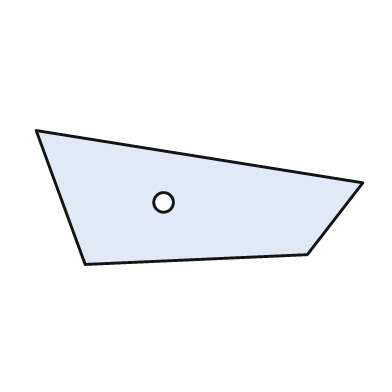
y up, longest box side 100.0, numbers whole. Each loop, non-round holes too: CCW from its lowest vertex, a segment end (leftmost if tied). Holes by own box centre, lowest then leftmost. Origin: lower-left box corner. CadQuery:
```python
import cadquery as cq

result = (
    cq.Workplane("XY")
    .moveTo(15.0, 0.0)
    .lineTo(83.0, 3.0)
    .lineTo(100.0, 25.0)
    .lineTo(0.0, 41.0)
    .close()
    .moveTo(39.0, 19.0)
    .circle(3.0)
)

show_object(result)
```